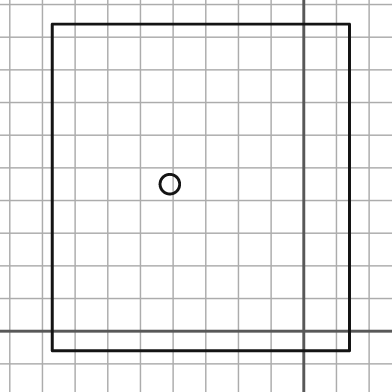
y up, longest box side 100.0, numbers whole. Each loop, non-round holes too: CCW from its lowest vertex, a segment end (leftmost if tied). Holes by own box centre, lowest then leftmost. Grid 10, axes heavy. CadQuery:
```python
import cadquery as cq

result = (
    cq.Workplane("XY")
    .moveTo(-77.0, -6.0)
    .lineTo(14.0, -6.0)
    .lineTo(14.0, 94.0)
    .lineTo(-77.0, 94.0)
    .close()
    .moveTo(-41.0, 45.0)
    .circle(3.0)
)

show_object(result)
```